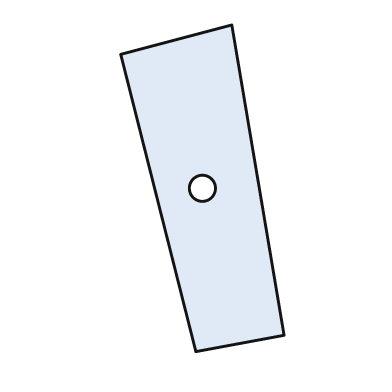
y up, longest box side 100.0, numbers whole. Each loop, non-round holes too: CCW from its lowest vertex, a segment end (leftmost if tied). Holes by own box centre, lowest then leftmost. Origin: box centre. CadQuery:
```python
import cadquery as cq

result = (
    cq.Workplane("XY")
    .moveTo(-2.0, -50.0)
    .lineTo(25.0, -45.0)
    .lineTo(9.0, 50.0)
    .lineTo(-25.0, 41.0)
    .close()
    .moveTo(0.0, 0.0)
    .circle(4.0)
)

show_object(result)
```